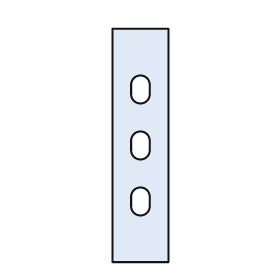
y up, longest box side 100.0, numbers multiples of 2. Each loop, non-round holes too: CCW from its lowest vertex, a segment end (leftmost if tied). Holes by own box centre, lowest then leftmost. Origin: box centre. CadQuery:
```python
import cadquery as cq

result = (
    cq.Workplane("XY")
    .moveTo(-12.0, -50.0)
    .lineTo(12.0, -50.0)
    .lineTo(12.0, 50.0)
    .lineTo(-12.0, 50.0)
    .close()
    .moveTo(-4.0, -26.0)
    .threePointArc((0.0, -30.0), (4.0, -26.0))
    .lineTo(4.0, -22.0)
    .threePointArc((0.0, -18.0), (-4.0, -22.0))
    .close()
    .moveTo(-4.0, -2.0)
    .threePointArc((0.0, -6.0), (4.0, -2.0))
    .lineTo(4.0, 2.0)
    .threePointArc((0.0, 6.0), (-4.0, 2.0))
    .close()
    .moveTo(-4.0, 22.0)
    .threePointArc((0.0, 18.0), (4.0, 22.0))
    .lineTo(4.0, 26.0)
    .threePointArc((0.0, 30.0), (-4.0, 26.0))
    .close()
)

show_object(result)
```